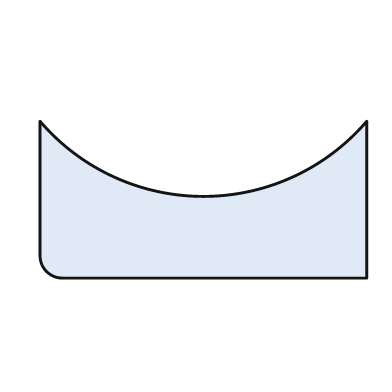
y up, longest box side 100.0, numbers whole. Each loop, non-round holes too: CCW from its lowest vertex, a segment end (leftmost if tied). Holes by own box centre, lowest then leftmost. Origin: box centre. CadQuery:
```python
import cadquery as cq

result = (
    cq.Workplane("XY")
    .moveTo(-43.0, -24.0)
    .lineTo(50.0, -24.0)
    .lineTo(50.0, 24.0)
    .threePointArc((0.0, 1.0), (-50.0, 24.0))
    .lineTo(-50.0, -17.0)
    .threePointArc((-48.0, -22.0), (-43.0, -24.0))
    .close()
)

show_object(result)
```